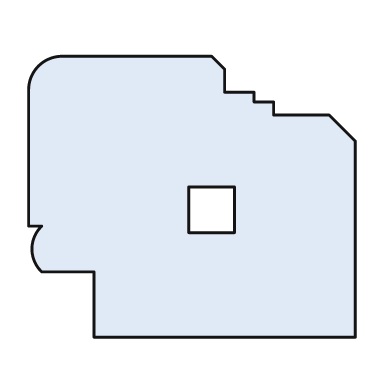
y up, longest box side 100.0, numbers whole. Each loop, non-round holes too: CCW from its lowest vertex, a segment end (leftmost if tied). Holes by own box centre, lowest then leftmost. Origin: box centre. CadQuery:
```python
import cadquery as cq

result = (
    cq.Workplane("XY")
    .moveTo(-30.0, -43.0)
    .lineTo(50.0, -43.0)
    .lineTo(50.0, 17.0)
    .lineTo(42.0, 25.0)
    .lineTo(25.0, 25.0)
    .lineTo(25.0, 29.0)
    .lineTo(19.0, 29.0)
    .lineTo(19.0, 32.0)
    .lineTo(10.0, 32.0)
    .lineTo(10.0, 39.0)
    .lineTo(6.0, 43.0)
    .lineTo(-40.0, 43.0)
    .threePointArc((-47.0, 40.0), (-50.0, 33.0))
    .lineTo(-50.0, -9.0)
    .lineTo(-46.0, -9.0)
    .threePointArc((-49.0, -16.0), (-46.0, -23.0))
    .lineTo(-30.0, -23.0)
    .close()
    .moveTo(-1.0, -11.0)
    .lineTo(13.0, -11.0)
    .lineTo(13.0, 3.0)
    .lineTo(-1.0, 3.0)
    .close()
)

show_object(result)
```